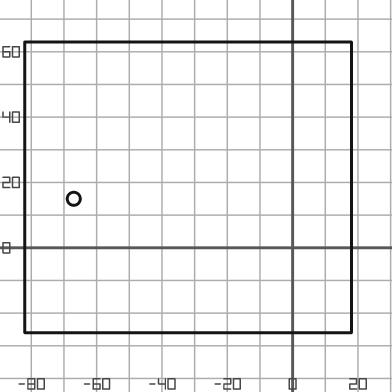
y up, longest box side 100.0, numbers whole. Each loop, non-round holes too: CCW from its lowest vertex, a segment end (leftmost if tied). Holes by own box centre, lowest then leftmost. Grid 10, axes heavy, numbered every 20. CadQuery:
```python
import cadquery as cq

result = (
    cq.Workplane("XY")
    .moveTo(-82.0, -26.0)
    .lineTo(18.0, -26.0)
    .lineTo(18.0, 63.0)
    .lineTo(-82.0, 63.0)
    .close()
    .moveTo(-67.0, 15.0)
    .circle(2.0)
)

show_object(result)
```